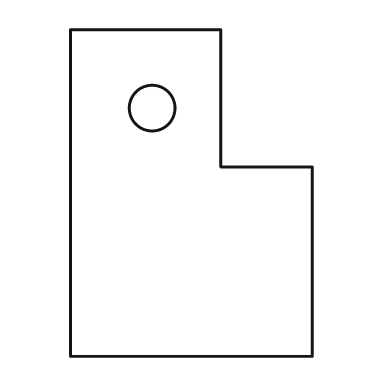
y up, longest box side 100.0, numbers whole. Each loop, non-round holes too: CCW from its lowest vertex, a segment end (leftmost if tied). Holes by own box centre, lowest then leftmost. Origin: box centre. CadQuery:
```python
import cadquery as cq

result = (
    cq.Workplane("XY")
    .moveTo(-37.0, -50.0)
    .lineTo(37.0, -50.0)
    .lineTo(37.0, 8.0)
    .lineTo(9.0, 8.0)
    .lineTo(9.0, 50.0)
    .lineTo(-37.0, 50.0)
    .close()
    .moveTo(-12.0, 26.0)
    .circle(7.0)
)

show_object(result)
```